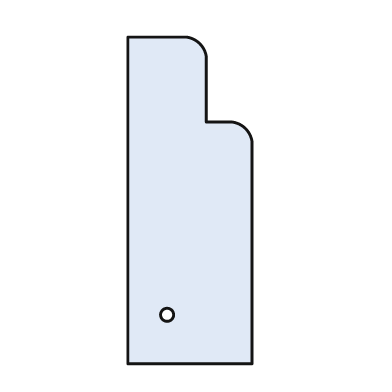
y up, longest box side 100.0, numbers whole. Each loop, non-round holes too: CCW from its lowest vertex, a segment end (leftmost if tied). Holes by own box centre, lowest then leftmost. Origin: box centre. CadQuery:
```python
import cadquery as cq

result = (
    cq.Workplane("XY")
    .moveTo(-19.0, -50.0)
    .lineTo(19.0, -50.0)
    .lineTo(19.0, 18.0)
    .threePointArc((17.0, 22.0), (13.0, 24.0))
    .lineTo(5.0, 24.0)
    .lineTo(5.0, 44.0)
    .threePointArc((3.0, 48.0), (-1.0, 50.0))
    .lineTo(-19.0, 50.0)
    .close()
    .moveTo(-7.0, -35.0)
    .circle(2.0)
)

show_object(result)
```